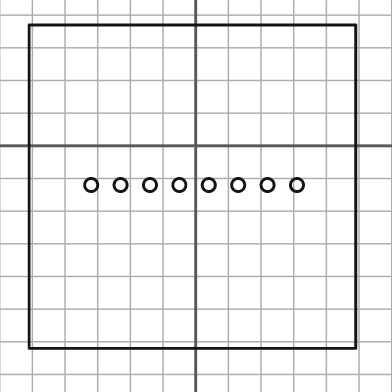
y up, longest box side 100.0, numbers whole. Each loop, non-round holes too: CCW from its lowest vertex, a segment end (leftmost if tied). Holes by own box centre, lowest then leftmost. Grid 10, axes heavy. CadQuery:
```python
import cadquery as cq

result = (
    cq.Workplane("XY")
    .moveTo(-51.0, -62.0)
    .lineTo(49.0, -62.0)
    .lineTo(49.0, 37.0)
    .lineTo(-51.0, 37.0)
    .close()
    .moveTo(-32.0, -12.0)
    .circle(2.0)
    .moveTo(-23.0, -12.0)
    .circle(2.0)
    .moveTo(-14.0, -12.0)
    .circle(2.0)
    .moveTo(-5.0, -12.0)
    .circle(2.0)
    .moveTo(4.0, -12.0)
    .circle(2.0)
    .moveTo(13.0, -12.0)
    .circle(2.0)
    .moveTo(22.0, -12.0)
    .circle(2.0)
    .moveTo(31.0, -12.0)
    .circle(2.0)
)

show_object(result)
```